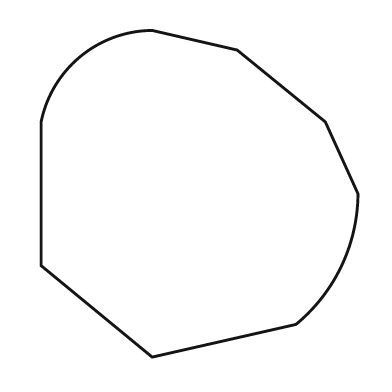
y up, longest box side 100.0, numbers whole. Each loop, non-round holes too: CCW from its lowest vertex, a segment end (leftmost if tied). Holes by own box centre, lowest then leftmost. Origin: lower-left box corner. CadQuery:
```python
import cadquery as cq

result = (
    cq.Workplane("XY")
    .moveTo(34.0, 0.0)
    .lineTo(78.0, 10.0)
    .threePointArc((92.0, 28.0), (97.0, 50.0))
    .lineTo(87.0, 72.0)
    .lineTo(60.0, 94.0)
    .lineTo(34.0, 100.0)
    .threePointArc((12.0, 92.0), (0.0, 72.0))
    .lineTo(0.0, 28.0)
    .close()
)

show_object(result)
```